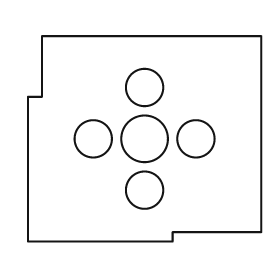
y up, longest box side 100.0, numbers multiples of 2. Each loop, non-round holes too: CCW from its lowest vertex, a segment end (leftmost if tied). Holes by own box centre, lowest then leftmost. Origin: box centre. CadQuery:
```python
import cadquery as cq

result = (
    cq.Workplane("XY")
    .moveTo(-50.0, -44.0)
    .lineTo(12.0, -44.0)
    .lineTo(12.0, -40.0)
    .lineTo(50.0, -40.0)
    .lineTo(50.0, 44.0)
    .lineTo(-44.0, 44.0)
    .lineTo(-44.0, 18.0)
    .lineTo(-50.0, 18.0)
    .close()
    .moveTo(0.0, -22.0)
    .circle(8.0)
    .moveTo(-22.0, 0.0)
    .circle(8.0)
    .moveTo(0.0, 0.0)
    .circle(10.0)
    .moveTo(22.0, 0.0)
    .circle(8.0)
    .moveTo(0.0, 22.0)
    .circle(8.0)
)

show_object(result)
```